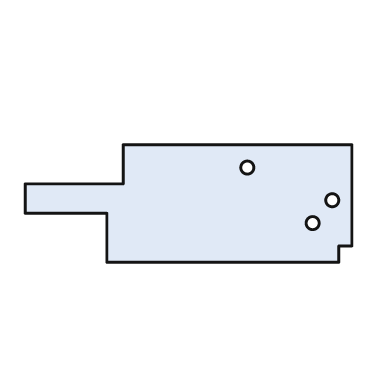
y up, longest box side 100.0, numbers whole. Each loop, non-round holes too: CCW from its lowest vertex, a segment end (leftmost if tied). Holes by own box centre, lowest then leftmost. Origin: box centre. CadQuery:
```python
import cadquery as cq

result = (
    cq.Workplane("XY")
    .moveTo(-25.0, -18.0)
    .lineTo(46.0, -18.0)
    .lineTo(46.0, -13.0)
    .lineTo(50.0, -13.0)
    .lineTo(50.0, 18.0)
    .lineTo(-20.0, 18.0)
    .lineTo(-20.0, 6.0)
    .lineTo(-50.0, 6.0)
    .lineTo(-50.0, -3.0)
    .lineTo(-25.0, -3.0)
    .close()
    .moveTo(38.0, -6.0)
    .circle(2.0)
    .moveTo(44.0, 1.0)
    .circle(2.0)
    .moveTo(18.0, 11.0)
    .circle(2.0)
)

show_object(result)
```